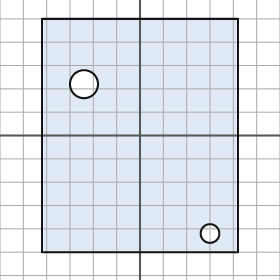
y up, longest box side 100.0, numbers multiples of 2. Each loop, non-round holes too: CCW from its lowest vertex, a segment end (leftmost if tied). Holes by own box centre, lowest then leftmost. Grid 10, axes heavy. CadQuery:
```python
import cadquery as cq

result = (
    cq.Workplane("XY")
    .moveTo(-42.0, -50.0)
    .lineTo(42.0, -50.0)
    .lineTo(42.0, 50.0)
    .lineTo(-42.0, 50.0)
    .close()
    .moveTo(30.0, -42.0)
    .circle(4.0)
    .moveTo(-24.0, 22.0)
    .circle(6.0)
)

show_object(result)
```